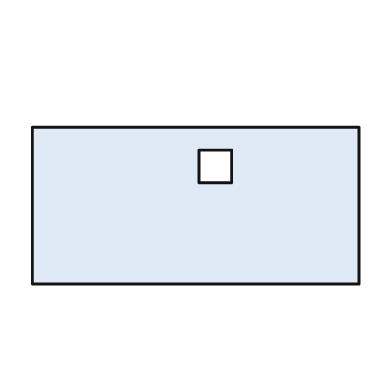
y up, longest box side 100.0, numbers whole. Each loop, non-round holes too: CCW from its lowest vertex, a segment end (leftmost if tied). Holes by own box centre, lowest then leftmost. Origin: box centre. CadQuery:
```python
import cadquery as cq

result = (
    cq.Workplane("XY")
    .moveTo(-50.0, -24.0)
    .lineTo(50.0, -24.0)
    .lineTo(50.0, 24.0)
    .lineTo(-50.0, 24.0)
    .close()
    .moveTo(1.0, 7.0)
    .lineTo(11.0, 7.0)
    .lineTo(11.0, 17.0)
    .lineTo(1.0, 17.0)
    .close()
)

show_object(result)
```